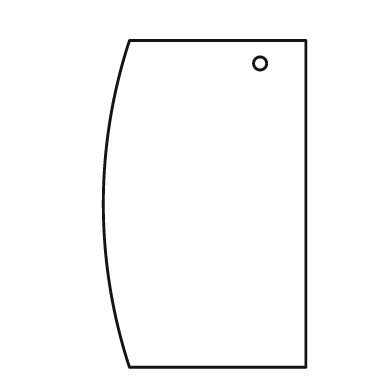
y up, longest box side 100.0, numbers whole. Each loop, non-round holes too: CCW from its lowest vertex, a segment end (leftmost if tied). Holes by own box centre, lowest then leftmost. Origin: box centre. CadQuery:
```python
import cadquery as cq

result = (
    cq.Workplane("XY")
    .moveTo(-23.0, -50.0)
    .lineTo(31.0, -50.0)
    .lineTo(31.0, 50.0)
    .lineTo(-23.0, 50.0)
    .threePointArc((-31.0, 0.0), (-23.0, -50.0))
    .close()
    .moveTo(17.0, 43.0)
    .circle(2.0)
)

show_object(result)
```